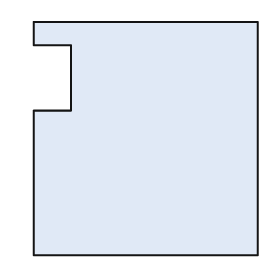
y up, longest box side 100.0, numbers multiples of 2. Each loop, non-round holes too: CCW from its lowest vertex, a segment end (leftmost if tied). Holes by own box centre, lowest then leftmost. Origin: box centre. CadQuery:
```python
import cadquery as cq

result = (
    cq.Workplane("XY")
    .moveTo(-48.0, -50.0)
    .lineTo(48.0, -50.0)
    .lineTo(48.0, 50.0)
    .lineTo(-48.0, 50.0)
    .lineTo(-48.0, 40.0)
    .lineTo(-32.0, 40.0)
    .lineTo(-32.0, 12.0)
    .lineTo(-48.0, 12.0)
    .close()
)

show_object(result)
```